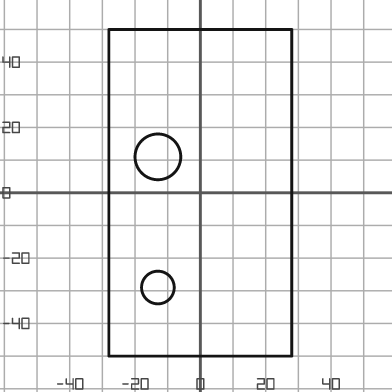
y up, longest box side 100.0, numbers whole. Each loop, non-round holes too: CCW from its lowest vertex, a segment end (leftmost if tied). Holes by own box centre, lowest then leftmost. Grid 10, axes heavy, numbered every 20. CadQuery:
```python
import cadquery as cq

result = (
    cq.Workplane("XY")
    .moveTo(-28.0, -50.0)
    .lineTo(28.0, -50.0)
    .lineTo(28.0, 50.0)
    .lineTo(-28.0, 50.0)
    .close()
    .moveTo(-13.0, -29.0)
    .circle(5.0)
    .moveTo(-13.0, 11.0)
    .circle(7.0)
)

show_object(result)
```